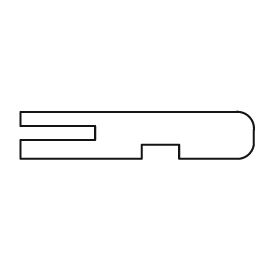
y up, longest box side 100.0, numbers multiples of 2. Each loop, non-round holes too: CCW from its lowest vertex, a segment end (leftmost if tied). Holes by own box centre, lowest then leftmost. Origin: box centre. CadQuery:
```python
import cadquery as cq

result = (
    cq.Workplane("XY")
    .moveTo(-50.0, -10.0)
    .lineTo(2.0, -10.0)
    .lineTo(2.0, -4.0)
    .lineTo(18.0, -4.0)
    .lineTo(18.0, -10.0)
    .lineTo(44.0, -10.0)
    .threePointArc((48.0, -8.0), (50.0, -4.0))
    .lineTo(50.0, 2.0)
    .threePointArc((48.0, 8.0), (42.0, 10.0))
    .lineTo(-50.0, 10.0)
    .lineTo(-50.0, 4.0)
    .lineTo(-18.0, 4.0)
    .lineTo(-18.0, -2.0)
    .lineTo(-50.0, -2.0)
    .close()
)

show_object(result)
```